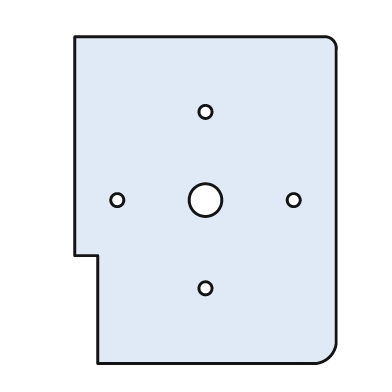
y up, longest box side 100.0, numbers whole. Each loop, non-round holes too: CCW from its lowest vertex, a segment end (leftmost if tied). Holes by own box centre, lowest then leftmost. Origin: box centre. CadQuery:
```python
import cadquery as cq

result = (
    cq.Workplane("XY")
    .moveTo(-33.0, -50.0)
    .lineTo(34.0, -50.0)
    .threePointArc((38.0, -48.0), (40.0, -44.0))
    .lineTo(40.0, 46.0)
    .threePointArc((39.0, 49.0), (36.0, 50.0))
    .lineTo(-40.0, 50.0)
    .lineTo(-40.0, -17.0)
    .lineTo(-33.0, -17.0)
    .close()
    .moveTo(0.0, -27.0)
    .circle(2.0)
    .moveTo(-27.0, 0.0)
    .circle(2.0)
    .moveTo(0.0, 0.0)
    .circle(5.0)
    .moveTo(27.0, 0.0)
    .circle(2.0)
    .moveTo(0.0, 27.0)
    .circle(2.0)
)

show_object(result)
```